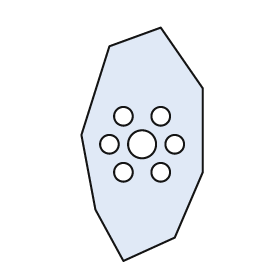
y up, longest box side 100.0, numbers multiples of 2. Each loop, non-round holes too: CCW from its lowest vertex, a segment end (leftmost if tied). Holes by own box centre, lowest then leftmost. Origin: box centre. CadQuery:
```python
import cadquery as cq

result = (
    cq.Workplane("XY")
    .moveTo(-8.0, -50.0)
    .lineTo(14.0, -40.0)
    .lineTo(26.0, -12.0)
    .lineTo(26.0, 24.0)
    .lineTo(8.0, 50.0)
    .lineTo(-14.0, 42.0)
    .lineTo(-26.0, 4.0)
    .lineTo(-20.0, -28.0)
    .close()
    .moveTo(-8.0, -12.0)
    .circle(4.0)
    .moveTo(8.0, -12.0)
    .circle(4.0)
    .moveTo(-14.0, 0.0)
    .circle(4.0)
    .moveTo(0.0, 0.0)
    .circle(6.0)
    .moveTo(14.0, 0.0)
    .circle(4.0)
    .moveTo(-8.0, 12.0)
    .circle(4.0)
    .moveTo(8.0, 12.0)
    .circle(4.0)
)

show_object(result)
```